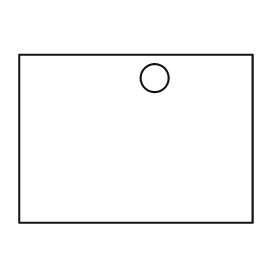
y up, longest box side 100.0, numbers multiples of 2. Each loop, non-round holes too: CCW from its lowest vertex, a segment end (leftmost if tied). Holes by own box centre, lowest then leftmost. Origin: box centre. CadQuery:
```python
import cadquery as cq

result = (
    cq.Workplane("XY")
    .moveTo(-50.0, -36.0)
    .lineTo(50.0, -36.0)
    .lineTo(50.0, 36.0)
    .lineTo(-50.0, 36.0)
    .close()
    .moveTo(8.0, 26.0)
    .circle(6.0)
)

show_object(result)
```